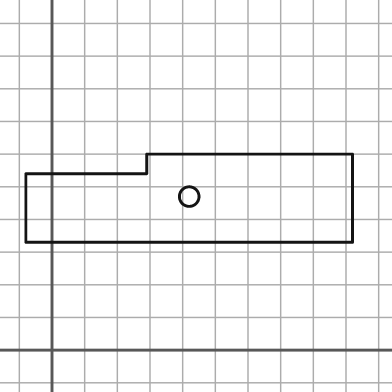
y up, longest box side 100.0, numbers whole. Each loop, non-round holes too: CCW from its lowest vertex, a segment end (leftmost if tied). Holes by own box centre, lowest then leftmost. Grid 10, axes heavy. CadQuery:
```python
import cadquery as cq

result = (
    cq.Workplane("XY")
    .moveTo(-8.0, 33.0)
    .lineTo(92.0, 33.0)
    .lineTo(92.0, 60.0)
    .lineTo(29.0, 60.0)
    .lineTo(29.0, 54.0)
    .lineTo(-8.0, 54.0)
    .close()
    .moveTo(42.0, 47.0)
    .circle(3.0)
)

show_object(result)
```